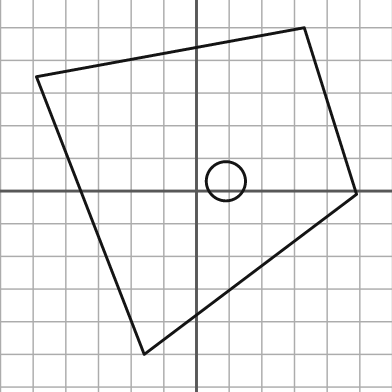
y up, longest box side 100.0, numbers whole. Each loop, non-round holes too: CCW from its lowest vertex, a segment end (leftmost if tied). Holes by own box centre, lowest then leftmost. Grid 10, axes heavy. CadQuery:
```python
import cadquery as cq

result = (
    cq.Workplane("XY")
    .moveTo(-16.0, -50.0)
    .lineTo(49.0, -1.0)
    .lineTo(33.0, 50.0)
    .lineTo(-49.0, 35.0)
    .close()
    .moveTo(9.0, 3.0)
    .circle(6.0)
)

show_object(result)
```